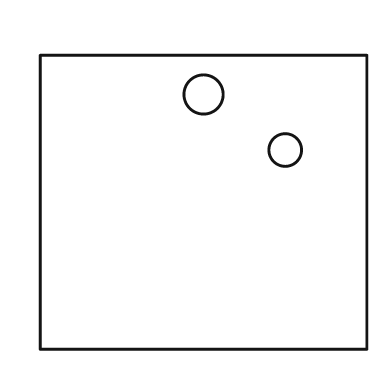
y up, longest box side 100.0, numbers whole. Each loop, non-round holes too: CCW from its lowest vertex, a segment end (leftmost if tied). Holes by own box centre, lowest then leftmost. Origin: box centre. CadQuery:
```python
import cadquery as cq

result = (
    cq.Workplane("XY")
    .moveTo(-50.0, -45.0)
    .lineTo(50.0, -45.0)
    .lineTo(50.0, 45.0)
    .lineTo(-50.0, 45.0)
    .close()
    .moveTo(25.0, 16.0)
    .circle(5.0)
    .moveTo(0.0, 33.0)
    .circle(6.0)
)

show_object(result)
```